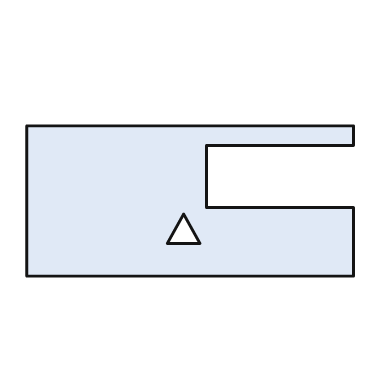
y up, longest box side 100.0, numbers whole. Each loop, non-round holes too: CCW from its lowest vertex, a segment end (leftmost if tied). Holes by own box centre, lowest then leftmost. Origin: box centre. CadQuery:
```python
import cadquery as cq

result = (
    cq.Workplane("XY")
    .moveTo(-50.0, -23.0)
    .lineTo(50.0, -23.0)
    .lineTo(50.0, -2.0)
    .lineTo(5.0, -2.0)
    .lineTo(5.0, 17.0)
    .lineTo(50.0, 17.0)
    .lineTo(50.0, 23.0)
    .lineTo(-50.0, 23.0)
    .close()
    .moveTo(-7.0, -13.0)
    .lineTo(3.0, -13.0)
    .lineTo(-2.0, -4.0)
    .close()
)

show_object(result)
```